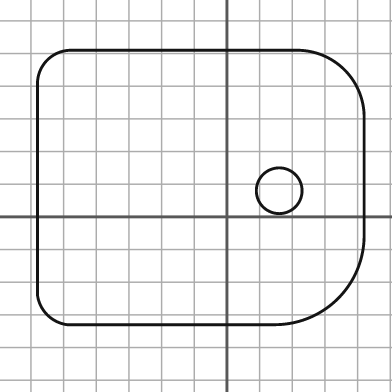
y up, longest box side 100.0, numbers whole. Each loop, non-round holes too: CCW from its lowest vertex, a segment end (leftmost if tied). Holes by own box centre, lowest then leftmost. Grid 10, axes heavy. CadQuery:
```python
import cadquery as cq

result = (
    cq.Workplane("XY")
    .moveTo(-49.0, -33.0)
    .lineTo(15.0, -33.0)
    .threePointArc((34.0, -25.0), (42.0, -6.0))
    .lineTo(42.0, 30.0)
    .threePointArc((36.0, 45.0), (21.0, 51.0))
    .lineTo(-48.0, 51.0)
    .threePointArc((-55.0, 48.0), (-58.0, 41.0))
    .lineTo(-58.0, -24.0)
    .threePointArc((-55.0, -30.0), (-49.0, -33.0))
    .close()
    .moveTo(16.0, 8.0)
    .circle(7.0)
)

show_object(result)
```